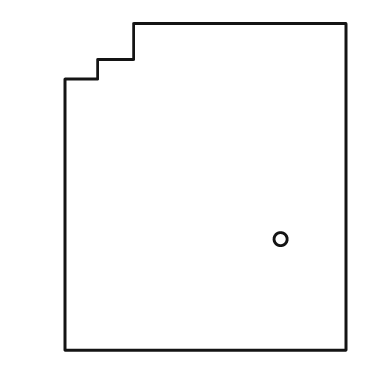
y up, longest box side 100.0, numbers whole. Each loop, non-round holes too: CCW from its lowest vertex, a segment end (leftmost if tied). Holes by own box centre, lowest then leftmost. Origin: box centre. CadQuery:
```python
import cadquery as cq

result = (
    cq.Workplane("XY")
    .moveTo(-43.0, -50.0)
    .lineTo(43.0, -50.0)
    .lineTo(43.0, 50.0)
    .lineTo(-22.0, 50.0)
    .lineTo(-22.0, 39.0)
    .lineTo(-33.0, 39.0)
    .lineTo(-33.0, 33.0)
    .lineTo(-43.0, 33.0)
    .close()
    .moveTo(23.0, -16.0)
    .circle(2.0)
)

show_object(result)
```